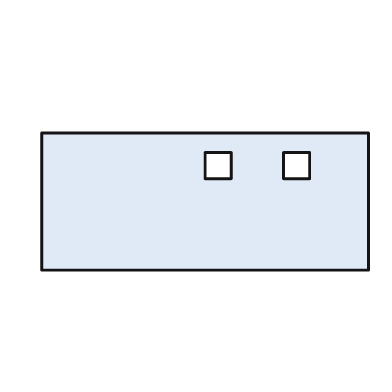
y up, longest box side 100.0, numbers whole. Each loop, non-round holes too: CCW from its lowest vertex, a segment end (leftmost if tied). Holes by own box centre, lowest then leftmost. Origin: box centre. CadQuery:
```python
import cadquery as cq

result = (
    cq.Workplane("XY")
    .moveTo(-50.0, -21.0)
    .lineTo(50.0, -21.0)
    .lineTo(50.0, 21.0)
    .lineTo(-50.0, 21.0)
    .close()
    .moveTo(0.0, 7.0)
    .lineTo(8.0, 7.0)
    .lineTo(8.0, 15.0)
    .lineTo(0.0, 15.0)
    .close()
    .moveTo(24.0, 7.0)
    .lineTo(32.0, 7.0)
    .lineTo(32.0, 15.0)
    .lineTo(24.0, 15.0)
    .close()
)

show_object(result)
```